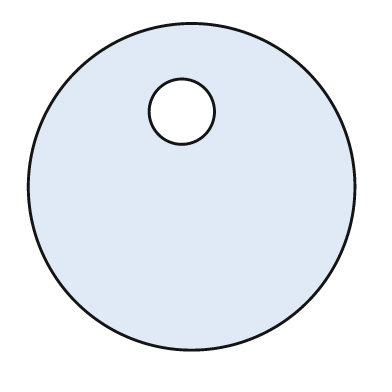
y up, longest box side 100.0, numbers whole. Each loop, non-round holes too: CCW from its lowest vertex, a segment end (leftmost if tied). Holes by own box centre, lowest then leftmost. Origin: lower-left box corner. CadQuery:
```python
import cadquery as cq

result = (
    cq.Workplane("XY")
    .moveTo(50.0, 50.0)
    .circle(50.0)
    .moveTo(47.0, 73.0)
    .circle(10.0)
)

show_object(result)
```